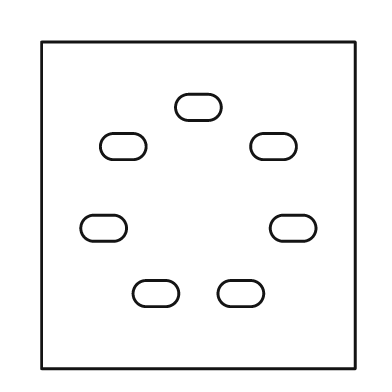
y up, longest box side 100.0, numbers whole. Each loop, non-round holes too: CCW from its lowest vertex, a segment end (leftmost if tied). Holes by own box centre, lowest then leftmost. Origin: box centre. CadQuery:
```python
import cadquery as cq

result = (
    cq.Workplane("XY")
    .moveTo(-48.0, -50.0)
    .lineTo(48.0, -50.0)
    .lineTo(48.0, 50.0)
    .lineTo(-48.0, 50.0)
    .close()
    .moveTo(-16.0, -31.0)
    .lineTo(-10.0, -31.0)
    .threePointArc((-6.0, -27.0), (-10.0, -23.0))
    .lineTo(-16.0, -23.0)
    .threePointArc((-20.0, -27.0), (-16.0, -31.0))
    .close()
    .moveTo(10.0, -31.0)
    .lineTo(16.0, -31.0)
    .threePointArc((20.0, -27.0), (16.0, -23.0))
    .lineTo(10.0, -23.0)
    .threePointArc((6.0, -27.0), (10.0, -31.0))
    .close()
    .moveTo(-32.0, -11.0)
    .lineTo(-26.0, -11.0)
    .threePointArc((-22.0, -7.0), (-26.0, -3.0))
    .lineTo(-32.0, -3.0)
    .threePointArc((-36.0, -7.0), (-32.0, -11.0))
    .close()
    .moveTo(26.0, -11.0)
    .lineTo(32.0, -11.0)
    .threePointArc((36.0, -7.0), (32.0, -3.0))
    .lineTo(26.0, -3.0)
    .threePointArc((22.0, -7.0), (26.0, -11.0))
    .close()
    .moveTo(-26.0, 14.0)
    .lineTo(-20.0, 14.0)
    .threePointArc((-16.0, 18.0), (-20.0, 22.0))
    .lineTo(-26.0, 22.0)
    .threePointArc((-30.0, 18.0), (-26.0, 14.0))
    .close()
    .moveTo(20.0, 14.0)
    .lineTo(26.0, 14.0)
    .threePointArc((30.0, 18.0), (26.0, 22.0))
    .lineTo(20.0, 22.0)
    .threePointArc((16.0, 18.0), (20.0, 14.0))
    .close()
    .moveTo(-3.0, 26.0)
    .lineTo(3.0, 26.0)
    .threePointArc((7.0, 30.0), (3.0, 34.0))
    .lineTo(-3.0, 34.0)
    .threePointArc((-7.0, 30.0), (-3.0, 26.0))
    .close()
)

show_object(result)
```